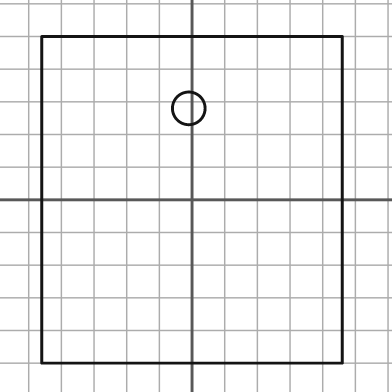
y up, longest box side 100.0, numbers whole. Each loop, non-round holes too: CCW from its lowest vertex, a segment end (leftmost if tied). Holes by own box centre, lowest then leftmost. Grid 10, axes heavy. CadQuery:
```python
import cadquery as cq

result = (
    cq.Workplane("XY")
    .moveTo(-46.0, -50.0)
    .lineTo(46.0, -50.0)
    .lineTo(46.0, 50.0)
    .lineTo(-46.0, 50.0)
    .close()
    .moveTo(-1.0, 28.0)
    .circle(5.0)
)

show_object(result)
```